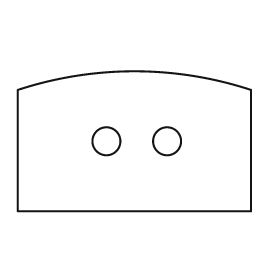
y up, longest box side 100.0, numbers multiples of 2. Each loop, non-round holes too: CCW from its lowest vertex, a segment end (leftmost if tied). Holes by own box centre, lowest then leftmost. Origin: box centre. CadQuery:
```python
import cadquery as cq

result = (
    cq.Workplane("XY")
    .moveTo(-50.0, -30.0)
    .lineTo(50.0, -30.0)
    .lineTo(50.0, 22.0)
    .threePointArc((0.0, 30.0), (-50.0, 22.0))
    .close()
    .moveTo(-12.0, 0.0)
    .circle(6.0)
    .moveTo(14.0, 0.0)
    .circle(6.0)
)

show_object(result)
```